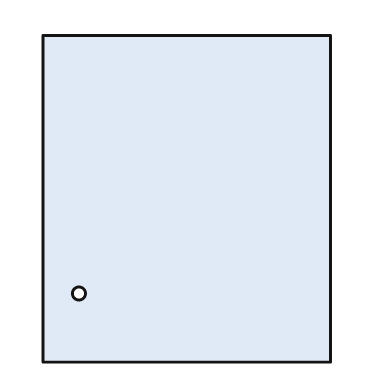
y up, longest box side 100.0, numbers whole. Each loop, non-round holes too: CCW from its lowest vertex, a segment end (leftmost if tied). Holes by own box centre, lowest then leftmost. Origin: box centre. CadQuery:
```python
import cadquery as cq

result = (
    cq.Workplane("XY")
    .moveTo(-44.0, -50.0)
    .lineTo(44.0, -50.0)
    .lineTo(44.0, 50.0)
    .lineTo(-44.0, 50.0)
    .close()
    .moveTo(-33.0, -29.0)
    .circle(2.0)
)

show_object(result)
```